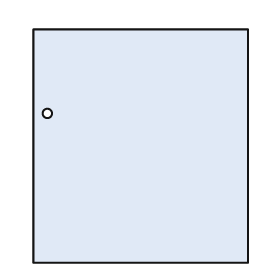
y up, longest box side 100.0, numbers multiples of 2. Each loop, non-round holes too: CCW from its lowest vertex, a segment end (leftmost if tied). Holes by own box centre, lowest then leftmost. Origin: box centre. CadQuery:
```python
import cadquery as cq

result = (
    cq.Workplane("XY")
    .moveTo(-46.0, -50.0)
    .lineTo(46.0, -50.0)
    .lineTo(46.0, 50.0)
    .lineTo(-46.0, 50.0)
    .close()
    .moveTo(-40.0, 14.0)
    .circle(2.0)
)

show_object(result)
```